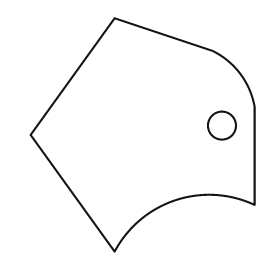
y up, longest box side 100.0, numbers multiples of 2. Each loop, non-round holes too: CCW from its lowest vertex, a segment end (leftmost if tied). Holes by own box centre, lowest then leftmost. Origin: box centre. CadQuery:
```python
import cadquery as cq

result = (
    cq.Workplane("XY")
    .moveTo(-12.0, -50.0)
    .threePointArc((14.0, -28.0), (48.0, -30.0))
    .lineTo(48.0, 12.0)
    .threePointArc((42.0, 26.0), (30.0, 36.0))
    .lineTo(-12.0, 50.0)
    .lineTo(-48.0, 0.0)
    .close()
    .moveTo(34.0, 4.0)
    .circle(6.0)
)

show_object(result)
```